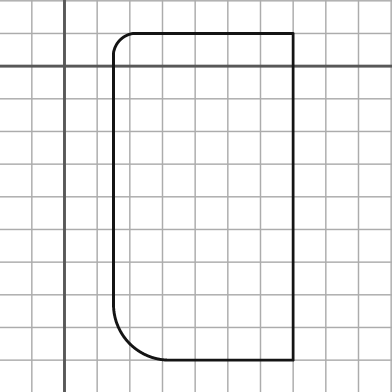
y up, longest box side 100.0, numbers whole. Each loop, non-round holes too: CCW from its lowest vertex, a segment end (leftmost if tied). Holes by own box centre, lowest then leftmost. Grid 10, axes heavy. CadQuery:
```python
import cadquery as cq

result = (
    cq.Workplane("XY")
    .moveTo(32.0, -90.0)
    .lineTo(70.0, -90.0)
    .lineTo(70.0, 10.0)
    .lineTo(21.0, 10.0)
    .threePointArc((17.0, 8.0), (15.0, 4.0))
    .lineTo(15.0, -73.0)
    .threePointArc((20.0, -85.0), (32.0, -90.0))
    .close()
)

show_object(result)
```